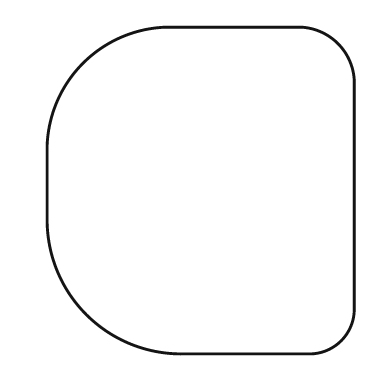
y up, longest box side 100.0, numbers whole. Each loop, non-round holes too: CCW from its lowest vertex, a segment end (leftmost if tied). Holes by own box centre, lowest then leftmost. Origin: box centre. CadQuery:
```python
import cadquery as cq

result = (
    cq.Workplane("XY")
    .moveTo(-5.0, -50.0)
    .lineTo(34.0, -50.0)
    .threePointArc((43.0, -46.0), (47.0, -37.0))
    .lineTo(47.0, 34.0)
    .threePointArc((42.0, 45.0), (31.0, 50.0))
    .lineTo(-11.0, 50.0)
    .threePointArc((-36.0, 39.0), (-47.0, 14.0))
    .lineTo(-47.0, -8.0)
    .threePointArc((-35.0, -38.0), (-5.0, -50.0))
    .close()
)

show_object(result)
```